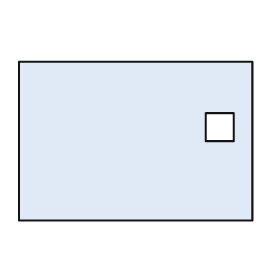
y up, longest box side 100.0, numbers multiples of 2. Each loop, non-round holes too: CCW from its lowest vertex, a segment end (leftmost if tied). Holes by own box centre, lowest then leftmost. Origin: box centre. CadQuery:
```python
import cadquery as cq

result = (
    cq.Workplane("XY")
    .moveTo(-50.0, -34.0)
    .lineTo(50.0, -34.0)
    .lineTo(50.0, 34.0)
    .lineTo(-50.0, 34.0)
    .close()
    .moveTo(30.0, 0.0)
    .lineTo(42.0, 0.0)
    .lineTo(42.0, 12.0)
    .lineTo(30.0, 12.0)
    .close()
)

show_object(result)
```